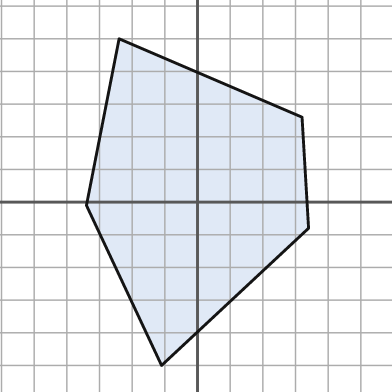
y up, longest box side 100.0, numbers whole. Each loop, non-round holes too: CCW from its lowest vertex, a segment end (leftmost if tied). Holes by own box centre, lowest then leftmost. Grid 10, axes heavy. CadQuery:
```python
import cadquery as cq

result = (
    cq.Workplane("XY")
    .moveTo(-11.0, -50.0)
    .lineTo(34.0, -8.0)
    .lineTo(32.0, 26.0)
    .lineTo(-24.0, 50.0)
    .lineTo(-34.0, -1.0)
    .close()
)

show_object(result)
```